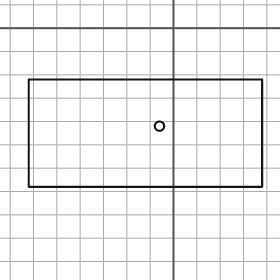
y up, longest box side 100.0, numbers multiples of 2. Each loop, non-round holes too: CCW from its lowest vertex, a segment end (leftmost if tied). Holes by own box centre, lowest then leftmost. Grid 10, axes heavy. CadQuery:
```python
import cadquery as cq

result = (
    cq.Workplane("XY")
    .moveTo(-62.0, -68.0)
    .lineTo(38.0, -68.0)
    .lineTo(38.0, -22.0)
    .lineTo(-62.0, -22.0)
    .close()
    .moveTo(-6.0, -42.0)
    .circle(2.0)
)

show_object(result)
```